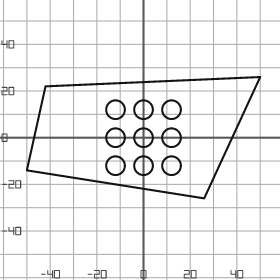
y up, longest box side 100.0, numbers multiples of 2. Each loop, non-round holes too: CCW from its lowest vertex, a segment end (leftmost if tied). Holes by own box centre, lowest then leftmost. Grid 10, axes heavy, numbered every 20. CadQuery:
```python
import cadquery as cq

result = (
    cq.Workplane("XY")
    .moveTo(26.0, -26.0)
    .lineTo(50.0, 26.0)
    .lineTo(-42.0, 22.0)
    .lineTo(-50.0, -14.0)
    .close()
    .moveTo(-12.0, -12.0)
    .circle(4.0)
    .moveTo(0.0, -12.0)
    .circle(4.0)
    .moveTo(12.0, -12.0)
    .circle(4.0)
    .moveTo(-12.0, 0.0)
    .circle(4.0)
    .moveTo(0.0, 0.0)
    .circle(4.0)
    .moveTo(12.0, 0.0)
    .circle(4.0)
    .moveTo(-12.0, 12.0)
    .circle(4.0)
    .moveTo(0.0, 12.0)
    .circle(4.0)
    .moveTo(12.0, 12.0)
    .circle(4.0)
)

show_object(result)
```